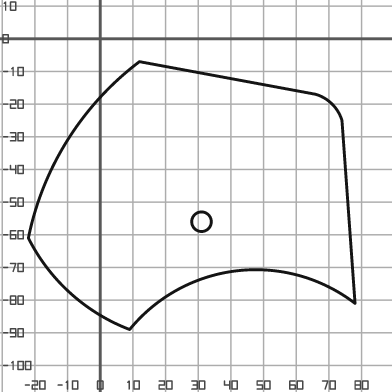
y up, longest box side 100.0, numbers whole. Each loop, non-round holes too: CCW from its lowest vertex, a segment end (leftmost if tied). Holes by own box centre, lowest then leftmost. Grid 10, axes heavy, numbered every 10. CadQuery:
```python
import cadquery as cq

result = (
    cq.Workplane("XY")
    .moveTo(9.0, -89.0)
    .threePointArc((42.0, -71.0), (78.0, -81.0))
    .lineTo(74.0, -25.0)
    .threePointArc((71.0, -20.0), (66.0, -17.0))
    .lineTo(12.0, -7.0)
    .threePointArc((-10.0, -31.0), (-22.0, -61.0))
    .threePointArc((-9.0, -78.0), (9.0, -89.0))
    .close()
    .moveTo(31.0, -56.0)
    .circle(3.0)
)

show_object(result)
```